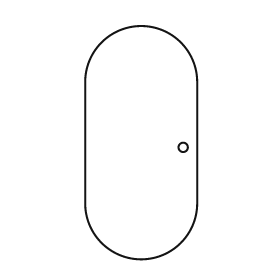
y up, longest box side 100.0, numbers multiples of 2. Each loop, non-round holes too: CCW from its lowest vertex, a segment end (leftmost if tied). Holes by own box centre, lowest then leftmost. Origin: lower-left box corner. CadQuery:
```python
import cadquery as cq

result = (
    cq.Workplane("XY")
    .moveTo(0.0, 24.0)
    .threePointArc((24.0, 0.0), (48.0, 24.0))
    .lineTo(48.0, 76.0)
    .threePointArc((24.0, 100.0), (0.0, 76.0))
    .close()
    .moveTo(42.0, 48.0)
    .circle(2.0)
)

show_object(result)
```